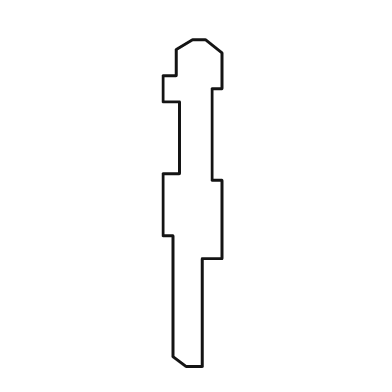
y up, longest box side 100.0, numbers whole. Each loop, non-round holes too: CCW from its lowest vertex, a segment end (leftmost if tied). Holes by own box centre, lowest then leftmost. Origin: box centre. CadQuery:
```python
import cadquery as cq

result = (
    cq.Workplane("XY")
    .moveTo(-2.0, -50.0)
    .lineTo(3.0, -50.0)
    .lineTo(3.0, -17.0)
    .lineTo(9.0, -17.0)
    .lineTo(9.0, 7.0)
    .lineTo(6.0, 7.0)
    .lineTo(6.0, 35.0)
    .lineTo(9.0, 35.0)
    .lineTo(9.0, 46.0)
    .lineTo(4.0, 50.0)
    .lineTo(0.0, 50.0)
    .lineTo(-5.0, 47.0)
    .lineTo(-5.0, 39.0)
    .lineTo(-9.0, 39.0)
    .lineTo(-9.0, 31.0)
    .lineTo(-4.0, 31.0)
    .lineTo(-4.0, 9.0)
    .lineTo(-9.0, 9.0)
    .lineTo(-9.0, -10.0)
    .lineTo(-6.0, -10.0)
    .lineTo(-6.0, -47.0)
    .close()
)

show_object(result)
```